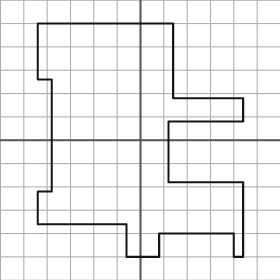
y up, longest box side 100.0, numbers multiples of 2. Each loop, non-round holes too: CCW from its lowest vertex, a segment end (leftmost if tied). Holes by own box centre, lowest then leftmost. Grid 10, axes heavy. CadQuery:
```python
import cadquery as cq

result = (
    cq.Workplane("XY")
    .moveTo(-6.0, -50.0)
    .lineTo(8.0, -50.0)
    .lineTo(8.0, -40.0)
    .lineTo(40.0, -40.0)
    .lineTo(40.0, -50.0)
    .lineTo(44.0, -50.0)
    .lineTo(44.0, -18.0)
    .lineTo(12.0, -18.0)
    .lineTo(12.0, 8.0)
    .lineTo(44.0, 8.0)
    .lineTo(44.0, 18.0)
    .lineTo(14.0, 18.0)
    .lineTo(14.0, 50.0)
    .lineTo(-44.0, 50.0)
    .lineTo(-44.0, 26.0)
    .lineTo(-38.0, 26.0)
    .lineTo(-38.0, -22.0)
    .lineTo(-44.0, -22.0)
    .lineTo(-44.0, -36.0)
    .lineTo(-6.0, -36.0)
    .close()
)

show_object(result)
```